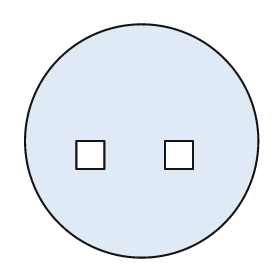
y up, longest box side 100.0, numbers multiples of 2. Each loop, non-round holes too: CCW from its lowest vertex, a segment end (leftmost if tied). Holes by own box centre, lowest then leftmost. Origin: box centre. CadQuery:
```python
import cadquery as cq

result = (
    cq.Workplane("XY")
    .moveTo(0.0, 0.0)
    .circle(50.0)
    .moveTo(-28.0, -12.0)
    .lineTo(-16.0, -12.0)
    .lineTo(-16.0, 0.0)
    .lineTo(-28.0, 0.0)
    .close()
    .moveTo(10.0, -12.0)
    .lineTo(22.0, -12.0)
    .lineTo(22.0, 0.0)
    .lineTo(10.0, 0.0)
    .close()
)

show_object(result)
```